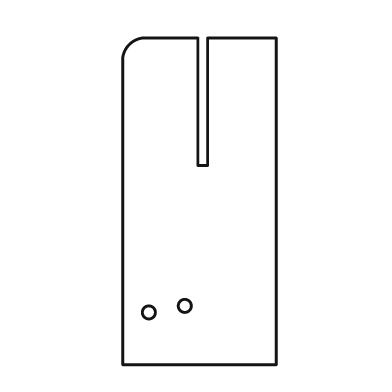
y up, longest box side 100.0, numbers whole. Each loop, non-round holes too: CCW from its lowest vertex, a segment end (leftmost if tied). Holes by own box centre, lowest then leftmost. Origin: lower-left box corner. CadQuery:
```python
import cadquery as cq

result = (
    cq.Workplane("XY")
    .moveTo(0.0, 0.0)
    .lineTo(47.0, 0.0)
    .lineTo(47.0, 100.0)
    .lineTo(26.0, 100.0)
    .lineTo(26.0, 61.0)
    .lineTo(23.0, 61.0)
    .lineTo(23.0, 100.0)
    .lineTo(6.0, 100.0)
    .threePointArc((2.0, 98.0), (0.0, 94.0))
    .close()
    .moveTo(8.0, 16.0)
    .circle(2.0)
    .moveTo(19.0, 18.0)
    .circle(2.0)
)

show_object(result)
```